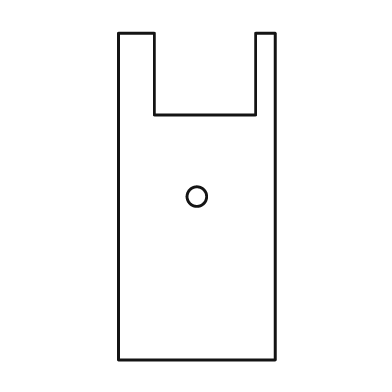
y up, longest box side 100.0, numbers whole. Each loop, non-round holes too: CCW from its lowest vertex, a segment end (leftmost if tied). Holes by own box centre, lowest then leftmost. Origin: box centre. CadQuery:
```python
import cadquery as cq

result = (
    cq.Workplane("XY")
    .moveTo(-24.0, -50.0)
    .lineTo(24.0, -50.0)
    .lineTo(24.0, 50.0)
    .lineTo(18.0, 50.0)
    .lineTo(18.0, 25.0)
    .lineTo(-13.0, 25.0)
    .lineTo(-13.0, 50.0)
    .lineTo(-24.0, 50.0)
    .close()
    .moveTo(0.0, 0.0)
    .circle(3.0)
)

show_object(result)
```